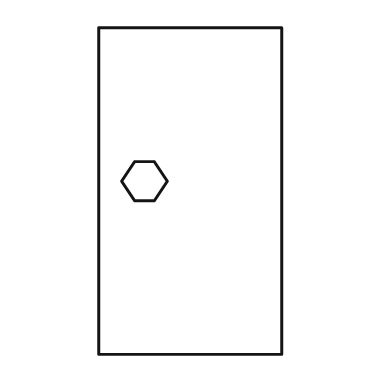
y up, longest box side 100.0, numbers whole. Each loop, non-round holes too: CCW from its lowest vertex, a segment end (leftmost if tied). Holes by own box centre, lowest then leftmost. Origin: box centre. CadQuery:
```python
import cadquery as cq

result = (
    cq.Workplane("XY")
    .moveTo(-28.0, -50.0)
    .lineTo(28.0, -50.0)
    .lineTo(28.0, 50.0)
    .lineTo(-28.0, 50.0)
    .close()
    .moveTo(-17.0, -3.0)
    .lineTo(-11.0, -3.0)
    .lineTo(-7.0, 3.0)
    .lineTo(-11.0, 9.0)
    .lineTo(-17.0, 9.0)
    .lineTo(-21.0, 3.0)
    .close()
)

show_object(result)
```